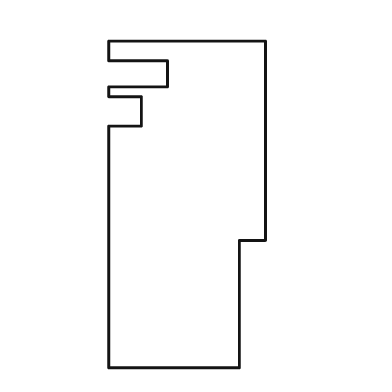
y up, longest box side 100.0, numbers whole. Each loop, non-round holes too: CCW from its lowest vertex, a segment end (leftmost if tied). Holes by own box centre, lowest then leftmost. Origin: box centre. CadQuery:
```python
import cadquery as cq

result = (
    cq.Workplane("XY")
    .moveTo(-24.0, -50.0)
    .lineTo(16.0, -50.0)
    .lineTo(16.0, -11.0)
    .lineTo(24.0, -11.0)
    .lineTo(24.0, 50.0)
    .lineTo(-24.0, 50.0)
    .lineTo(-24.0, 44.0)
    .lineTo(-6.0, 44.0)
    .lineTo(-6.0, 36.0)
    .lineTo(-24.0, 36.0)
    .lineTo(-24.0, 33.0)
    .lineTo(-14.0, 33.0)
    .lineTo(-14.0, 24.0)
    .lineTo(-24.0, 24.0)
    .close()
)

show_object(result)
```